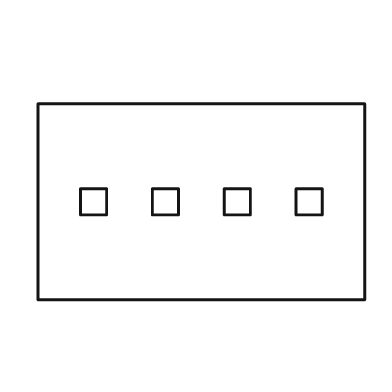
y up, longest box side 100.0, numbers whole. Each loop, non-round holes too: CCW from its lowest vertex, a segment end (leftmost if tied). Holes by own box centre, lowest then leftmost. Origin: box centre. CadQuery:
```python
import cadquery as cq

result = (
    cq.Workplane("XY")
    .moveTo(-50.0, -30.0)
    .lineTo(50.0, -30.0)
    .lineTo(50.0, 30.0)
    .lineTo(-50.0, 30.0)
    .close()
    .moveTo(-37.0, -4.0)
    .lineTo(-29.0, -4.0)
    .lineTo(-29.0, 4.0)
    .lineTo(-37.0, 4.0)
    .close()
    .moveTo(-15.0, -4.0)
    .lineTo(-7.0, -4.0)
    .lineTo(-7.0, 4.0)
    .lineTo(-15.0, 4.0)
    .close()
    .moveTo(7.0, -4.0)
    .lineTo(15.0, -4.0)
    .lineTo(15.0, 4.0)
    .lineTo(7.0, 4.0)
    .close()
    .moveTo(29.0, -4.0)
    .lineTo(37.0, -4.0)
    .lineTo(37.0, 4.0)
    .lineTo(29.0, 4.0)
    .close()
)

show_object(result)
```